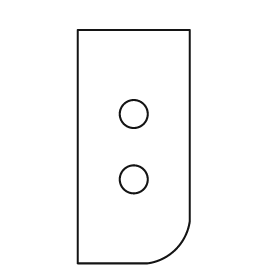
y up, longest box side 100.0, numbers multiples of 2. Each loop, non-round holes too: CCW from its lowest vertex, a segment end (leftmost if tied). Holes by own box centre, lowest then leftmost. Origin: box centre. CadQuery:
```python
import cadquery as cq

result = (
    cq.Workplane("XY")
    .moveTo(-24.0, -50.0)
    .lineTo(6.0, -50.0)
    .threePointArc((18.0, -44.0), (24.0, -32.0))
    .lineTo(24.0, 50.0)
    .lineTo(-24.0, 50.0)
    .close()
    .moveTo(0.0, -14.0)
    .circle(6.0)
    .moveTo(0.0, 14.0)
    .circle(6.0)
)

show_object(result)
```